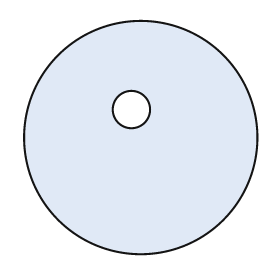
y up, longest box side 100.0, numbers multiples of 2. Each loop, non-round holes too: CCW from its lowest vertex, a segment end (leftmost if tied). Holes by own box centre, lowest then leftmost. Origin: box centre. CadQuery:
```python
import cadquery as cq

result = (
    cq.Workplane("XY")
    .moveTo(0.0, 0.0)
    .circle(50.0)
    .moveTo(-4.0, 12.0)
    .circle(8.0)
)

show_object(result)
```